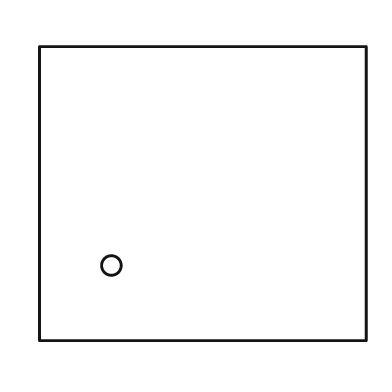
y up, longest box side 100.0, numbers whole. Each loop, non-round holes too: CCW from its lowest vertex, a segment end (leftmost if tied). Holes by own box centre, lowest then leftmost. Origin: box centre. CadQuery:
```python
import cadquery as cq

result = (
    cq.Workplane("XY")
    .moveTo(-50.0, -45.0)
    .lineTo(50.0, -45.0)
    .lineTo(50.0, 45.0)
    .lineTo(-50.0, 45.0)
    .close()
    .moveTo(-28.0, -22.0)
    .circle(3.0)
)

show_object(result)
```